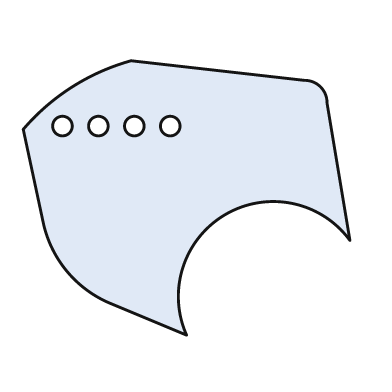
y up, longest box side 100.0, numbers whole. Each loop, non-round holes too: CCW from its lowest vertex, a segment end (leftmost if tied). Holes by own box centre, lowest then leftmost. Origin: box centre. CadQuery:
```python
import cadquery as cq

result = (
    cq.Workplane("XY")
    .moveTo(0.0, -42.0)
    .threePointArc((12.0, -5.0), (50.0, -13.0))
    .lineTo(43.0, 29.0)
    .threePointArc((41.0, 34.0), (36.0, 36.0))
    .lineTo(-17.0, 42.0)
    .threePointArc((-35.0, 34.0), (-50.0, 21.0))
    .lineTo(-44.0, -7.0)
    .threePointArc((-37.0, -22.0), (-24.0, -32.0))
    .close()
    .moveTo(-38.0, 22.0)
    .circle(3.0)
    .moveTo(-27.0, 22.0)
    .circle(3.0)
    .moveTo(-16.0, 22.0)
    .circle(3.0)
    .moveTo(-5.0, 22.0)
    .circle(3.0)
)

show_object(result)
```